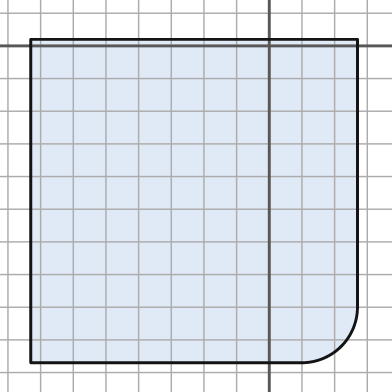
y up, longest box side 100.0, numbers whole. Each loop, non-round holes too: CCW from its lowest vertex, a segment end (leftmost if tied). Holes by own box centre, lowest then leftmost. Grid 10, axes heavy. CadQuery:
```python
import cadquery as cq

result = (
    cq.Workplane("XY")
    .moveTo(-73.0, -97.0)
    .lineTo(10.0, -97.0)
    .threePointArc((22.0, -92.0), (27.0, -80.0))
    .lineTo(27.0, 2.0)
    .lineTo(-73.0, 2.0)
    .close()
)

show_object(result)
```